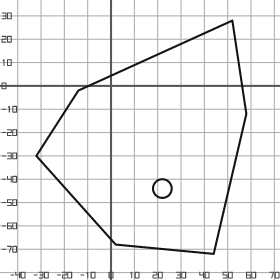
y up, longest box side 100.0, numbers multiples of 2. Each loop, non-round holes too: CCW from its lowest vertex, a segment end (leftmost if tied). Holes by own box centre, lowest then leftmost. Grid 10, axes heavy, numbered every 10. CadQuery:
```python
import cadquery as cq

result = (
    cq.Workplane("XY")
    .moveTo(44.0, -72.0)
    .lineTo(58.0, -12.0)
    .lineTo(52.0, 28.0)
    .lineTo(-14.0, -2.0)
    .lineTo(-32.0, -30.0)
    .lineTo(2.0, -68.0)
    .close()
    .moveTo(22.0, -44.0)
    .circle(4.0)
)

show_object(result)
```